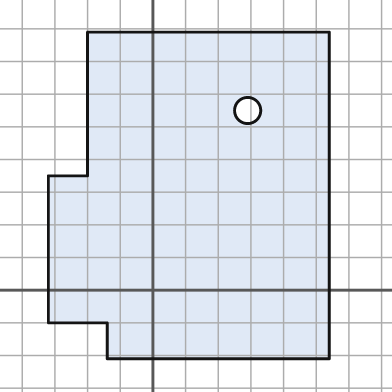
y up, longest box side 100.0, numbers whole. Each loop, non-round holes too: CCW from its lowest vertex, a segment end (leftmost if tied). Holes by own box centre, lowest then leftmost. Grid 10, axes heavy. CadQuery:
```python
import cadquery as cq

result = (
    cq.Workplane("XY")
    .moveTo(-14.0, -21.0)
    .lineTo(54.0, -21.0)
    .lineTo(54.0, 79.0)
    .lineTo(-20.0, 79.0)
    .lineTo(-20.0, 35.0)
    .lineTo(-32.0, 35.0)
    .lineTo(-32.0, -10.0)
    .lineTo(-14.0, -10.0)
    .close()
    .moveTo(29.0, 55.0)
    .circle(4.0)
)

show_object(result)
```